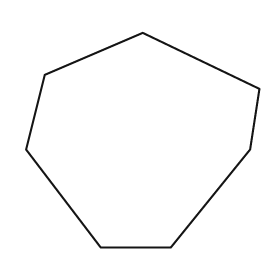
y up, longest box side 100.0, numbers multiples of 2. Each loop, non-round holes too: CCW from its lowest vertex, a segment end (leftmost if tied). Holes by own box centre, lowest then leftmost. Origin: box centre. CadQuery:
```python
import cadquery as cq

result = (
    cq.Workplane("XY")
    .moveTo(-18.0, -46.0)
    .lineTo(12.0, -46.0)
    .lineTo(46.0, -4.0)
    .lineTo(50.0, 22.0)
    .lineTo(0.0, 46.0)
    .lineTo(-42.0, 28.0)
    .lineTo(-50.0, -4.0)
    .close()
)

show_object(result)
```